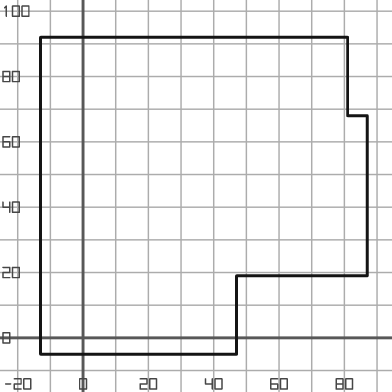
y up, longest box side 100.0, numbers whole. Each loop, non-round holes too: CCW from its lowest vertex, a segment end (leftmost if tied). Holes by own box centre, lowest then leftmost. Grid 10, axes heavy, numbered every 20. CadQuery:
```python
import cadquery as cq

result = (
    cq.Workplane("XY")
    .moveTo(-13.0, -5.0)
    .lineTo(47.0, -5.0)
    .lineTo(47.0, 19.0)
    .lineTo(87.0, 19.0)
    .lineTo(87.0, 68.0)
    .lineTo(81.0, 68.0)
    .lineTo(81.0, 92.0)
    .lineTo(-13.0, 92.0)
    .close()
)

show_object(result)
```